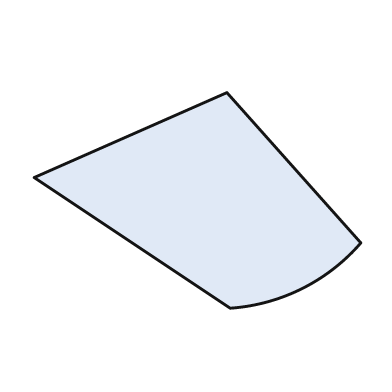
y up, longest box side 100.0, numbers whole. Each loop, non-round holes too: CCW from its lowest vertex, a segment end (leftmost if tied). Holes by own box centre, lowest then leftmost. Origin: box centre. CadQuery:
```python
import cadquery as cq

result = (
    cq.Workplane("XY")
    .moveTo(10.0, -33.0)
    .threePointArc((32.0, -27.0), (50.0, -13.0))
    .lineTo(9.0, 33.0)
    .lineTo(-50.0, 7.0)
    .close()
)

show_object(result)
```